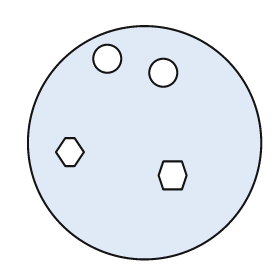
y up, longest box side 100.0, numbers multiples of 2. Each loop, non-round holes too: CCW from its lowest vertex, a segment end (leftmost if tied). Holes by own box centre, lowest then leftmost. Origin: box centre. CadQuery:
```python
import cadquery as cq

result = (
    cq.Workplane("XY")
    .moveTo(0.0, 0.0)
    .circle(50.0)
    .moveTo(8.0, -20.0)
    .lineTo(16.0, -20.0)
    .lineTo(18.0, -14.0)
    .lineTo(16.0, -8.0)
    .lineTo(8.0, -8.0)
    .lineTo(6.0, -14.0)
    .close()
    .moveTo(-34.0, -10.0)
    .lineTo(-30.0, -10.0)
    .lineTo(-26.0, -4.0)
    .lineTo(-30.0, 2.0)
    .lineTo(-34.0, 2.0)
    .lineTo(-38.0, -4.0)
    .close()
    .moveTo(8.0, 30.0)
    .circle(6.0)
    .moveTo(-16.0, 36.0)
    .circle(6.0)
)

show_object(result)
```